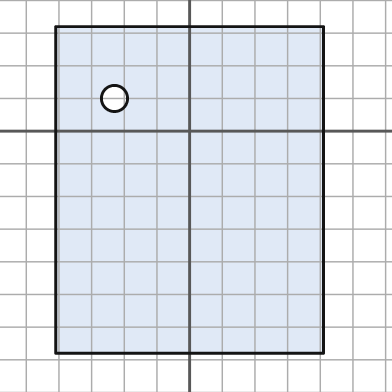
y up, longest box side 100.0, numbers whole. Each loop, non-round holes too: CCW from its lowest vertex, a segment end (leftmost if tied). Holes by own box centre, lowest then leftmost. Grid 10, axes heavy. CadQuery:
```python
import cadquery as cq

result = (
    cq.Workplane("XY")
    .moveTo(-41.0, -68.0)
    .lineTo(41.0, -68.0)
    .lineTo(41.0, 32.0)
    .lineTo(-41.0, 32.0)
    .close()
    .moveTo(-23.0, 10.0)
    .circle(4.0)
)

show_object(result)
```